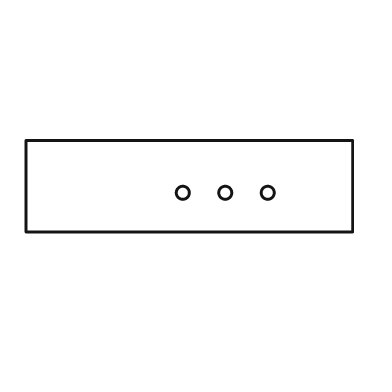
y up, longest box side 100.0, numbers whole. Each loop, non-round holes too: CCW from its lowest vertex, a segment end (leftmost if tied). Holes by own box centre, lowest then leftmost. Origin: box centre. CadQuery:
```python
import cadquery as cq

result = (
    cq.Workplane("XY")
    .moveTo(-50.0, -14.0)
    .lineTo(50.0, -14.0)
    .lineTo(50.0, 14.0)
    .lineTo(-50.0, 14.0)
    .close()
    .moveTo(-2.0, -2.0)
    .circle(2.0)
    .moveTo(11.0, -2.0)
    .circle(2.0)
    .moveTo(24.0, -2.0)
    .circle(2.0)
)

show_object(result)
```